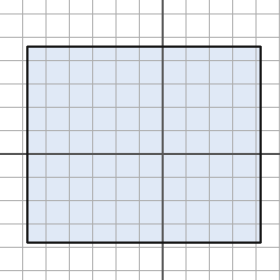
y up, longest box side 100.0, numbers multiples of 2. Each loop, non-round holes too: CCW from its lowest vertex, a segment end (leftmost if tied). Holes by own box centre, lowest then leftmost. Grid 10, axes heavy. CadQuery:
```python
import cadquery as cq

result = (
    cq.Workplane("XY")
    .moveTo(-58.0, -38.0)
    .lineTo(42.0, -38.0)
    .lineTo(42.0, 46.0)
    .lineTo(-58.0, 46.0)
    .close()
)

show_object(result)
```